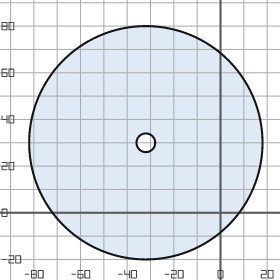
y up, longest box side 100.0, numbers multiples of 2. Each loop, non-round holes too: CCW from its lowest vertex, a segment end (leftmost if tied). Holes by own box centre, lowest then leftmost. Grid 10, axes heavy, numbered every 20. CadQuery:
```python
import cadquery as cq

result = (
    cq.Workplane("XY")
    .moveTo(-32.0, 30.0)
    .circle(50.0)
    .moveTo(-32.0, 30.0)
    .circle(4.0)
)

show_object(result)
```